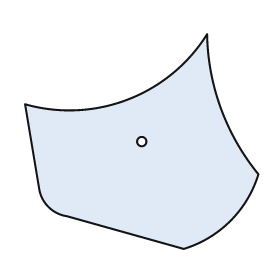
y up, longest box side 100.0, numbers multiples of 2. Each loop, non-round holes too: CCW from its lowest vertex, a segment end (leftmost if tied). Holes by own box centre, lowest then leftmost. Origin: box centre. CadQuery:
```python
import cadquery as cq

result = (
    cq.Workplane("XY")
    .moveTo(18.0, -46.0)
    .threePointArc((38.0, -34.0), (50.0, -14.0))
    .threePointArc((34.0, 14.0), (28.0, 46.0))
    .threePointArc((-6.0, 18.0), (-50.0, 16.0))
    .lineTo(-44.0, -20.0)
    .threePointArc((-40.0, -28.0), (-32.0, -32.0))
    .close()
    .moveTo(0.0, 0.0)
    .circle(2.0)
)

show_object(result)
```